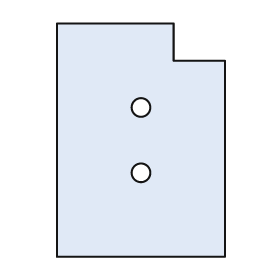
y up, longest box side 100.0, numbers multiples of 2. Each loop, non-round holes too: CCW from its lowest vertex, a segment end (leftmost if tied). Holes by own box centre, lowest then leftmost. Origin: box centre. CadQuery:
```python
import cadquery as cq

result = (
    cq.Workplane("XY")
    .moveTo(-36.0, -50.0)
    .lineTo(36.0, -50.0)
    .lineTo(36.0, 34.0)
    .lineTo(14.0, 34.0)
    .lineTo(14.0, 50.0)
    .lineTo(-36.0, 50.0)
    .close()
    .moveTo(0.0, -14.0)
    .circle(4.0)
    .moveTo(0.0, 14.0)
    .circle(4.0)
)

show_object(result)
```